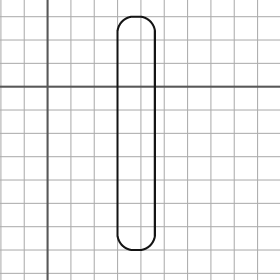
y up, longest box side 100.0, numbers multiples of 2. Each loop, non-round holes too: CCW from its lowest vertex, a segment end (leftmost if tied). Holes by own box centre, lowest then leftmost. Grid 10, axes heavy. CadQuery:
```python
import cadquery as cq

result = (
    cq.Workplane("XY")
    .moveTo(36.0, -70.0)
    .lineTo(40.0, -70.0)
    .threePointArc((44.0, -68.0), (46.0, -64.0))
    .lineTo(46.0, 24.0)
    .threePointArc((44.0, 28.0), (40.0, 30.0))
    .lineTo(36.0, 30.0)
    .threePointArc((32.0, 28.0), (30.0, 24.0))
    .lineTo(30.0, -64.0)
    .threePointArc((32.0, -68.0), (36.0, -70.0))
    .close()
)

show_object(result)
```